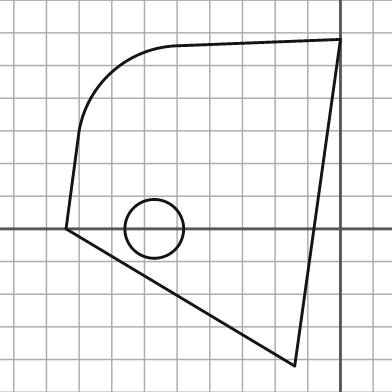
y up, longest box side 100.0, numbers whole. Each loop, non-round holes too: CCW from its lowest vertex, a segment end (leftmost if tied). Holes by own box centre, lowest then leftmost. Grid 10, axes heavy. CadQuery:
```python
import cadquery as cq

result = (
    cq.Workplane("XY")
    .moveTo(-14.0, -42.0)
    .lineTo(0.0, 58.0)
    .lineTo(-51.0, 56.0)
    .threePointArc((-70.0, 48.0), (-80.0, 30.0))
    .lineTo(-84.0, 0.0)
    .close()
    .moveTo(-57.0, 0.0)
    .circle(9.0)
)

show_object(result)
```